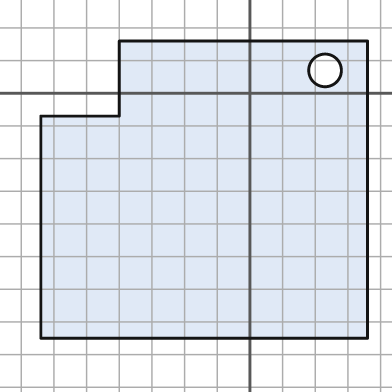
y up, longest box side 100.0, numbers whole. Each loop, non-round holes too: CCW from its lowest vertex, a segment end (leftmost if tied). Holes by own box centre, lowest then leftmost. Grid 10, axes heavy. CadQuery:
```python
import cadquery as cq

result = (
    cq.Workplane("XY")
    .moveTo(-64.0, -75.0)
    .lineTo(36.0, -75.0)
    .lineTo(36.0, 16.0)
    .lineTo(-40.0, 16.0)
    .lineTo(-40.0, -7.0)
    .lineTo(-64.0, -7.0)
    .close()
    .moveTo(23.0, 7.0)
    .circle(5.0)
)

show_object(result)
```